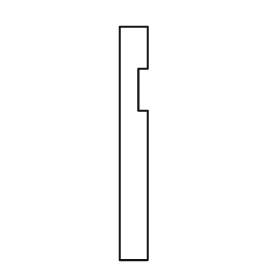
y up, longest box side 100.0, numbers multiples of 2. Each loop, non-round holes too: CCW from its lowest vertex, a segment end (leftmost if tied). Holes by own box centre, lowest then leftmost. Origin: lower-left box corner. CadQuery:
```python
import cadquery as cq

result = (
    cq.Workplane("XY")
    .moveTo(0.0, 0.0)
    .lineTo(12.0, 0.0)
    .lineTo(12.0, 64.0)
    .lineTo(8.0, 64.0)
    .lineTo(8.0, 82.0)
    .lineTo(12.0, 82.0)
    .lineTo(12.0, 100.0)
    .lineTo(0.0, 100.0)
    .close()
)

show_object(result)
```